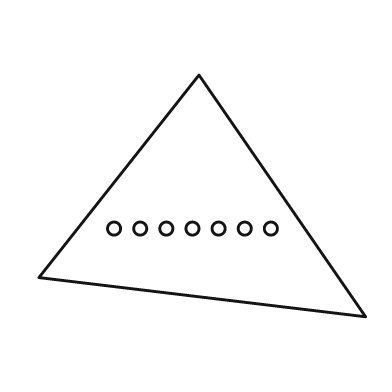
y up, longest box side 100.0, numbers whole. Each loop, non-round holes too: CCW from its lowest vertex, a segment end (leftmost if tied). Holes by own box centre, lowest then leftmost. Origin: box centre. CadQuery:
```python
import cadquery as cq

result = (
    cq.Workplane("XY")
    .moveTo(50.0, -37.0)
    .lineTo(-1.0, 37.0)
    .lineTo(-50.0, -25.0)
    .close()
    .moveTo(-27.0, -10.0)
    .circle(2.0)
    .moveTo(-19.0, -10.0)
    .circle(2.0)
    .moveTo(-11.0, -10.0)
    .circle(2.0)
    .moveTo(-3.0, -10.0)
    .circle(2.0)
    .moveTo(5.0, -10.0)
    .circle(2.0)
    .moveTo(13.0, -10.0)
    .circle(2.0)
    .moveTo(21.0, -10.0)
    .circle(2.0)
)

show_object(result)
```